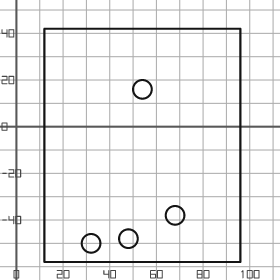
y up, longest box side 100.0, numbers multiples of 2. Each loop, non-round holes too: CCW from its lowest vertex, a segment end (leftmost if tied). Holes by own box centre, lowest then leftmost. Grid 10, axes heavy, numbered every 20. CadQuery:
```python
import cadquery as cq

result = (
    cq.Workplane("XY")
    .moveTo(12.0, -58.0)
    .lineTo(96.0, -58.0)
    .lineTo(96.0, 42.0)
    .lineTo(12.0, 42.0)
    .close()
    .moveTo(32.0, -50.0)
    .circle(4.0)
    .moveTo(48.0, -48.0)
    .circle(4.0)
    .moveTo(68.0, -38.0)
    .circle(4.0)
    .moveTo(54.0, 16.0)
    .circle(4.0)
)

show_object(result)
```